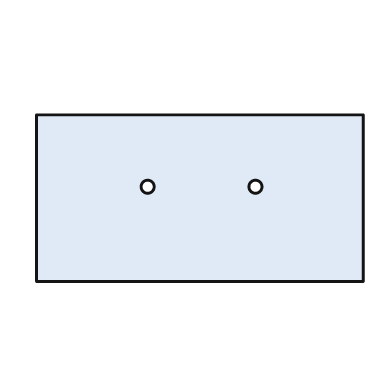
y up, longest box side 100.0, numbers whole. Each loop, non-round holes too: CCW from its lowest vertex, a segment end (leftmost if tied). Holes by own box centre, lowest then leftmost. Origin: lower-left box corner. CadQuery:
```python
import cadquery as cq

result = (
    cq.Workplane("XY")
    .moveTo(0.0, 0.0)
    .lineTo(100.0, 0.0)
    .lineTo(100.0, 51.0)
    .lineTo(0.0, 51.0)
    .close()
    .moveTo(34.0, 29.0)
    .circle(2.0)
    .moveTo(67.0, 29.0)
    .circle(2.0)
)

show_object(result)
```